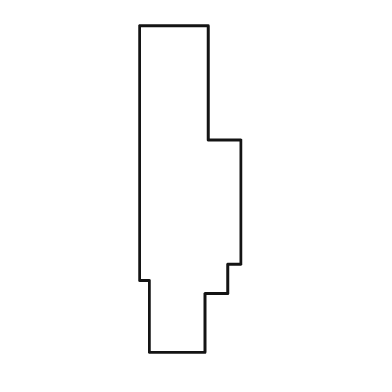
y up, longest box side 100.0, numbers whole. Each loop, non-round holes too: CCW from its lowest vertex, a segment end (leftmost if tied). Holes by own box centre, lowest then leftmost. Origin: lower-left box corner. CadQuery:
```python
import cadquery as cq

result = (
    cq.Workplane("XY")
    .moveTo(3.0, 0.0)
    .lineTo(20.0, 0.0)
    .lineTo(20.0, 18.0)
    .lineTo(27.0, 18.0)
    .lineTo(27.0, 27.0)
    .lineTo(31.0, 27.0)
    .lineTo(31.0, 65.0)
    .lineTo(21.0, 65.0)
    .lineTo(21.0, 100.0)
    .lineTo(0.0, 100.0)
    .lineTo(0.0, 22.0)
    .lineTo(3.0, 22.0)
    .close()
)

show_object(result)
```